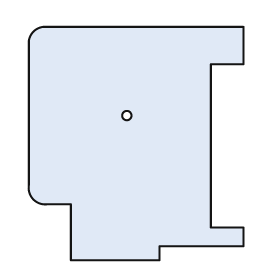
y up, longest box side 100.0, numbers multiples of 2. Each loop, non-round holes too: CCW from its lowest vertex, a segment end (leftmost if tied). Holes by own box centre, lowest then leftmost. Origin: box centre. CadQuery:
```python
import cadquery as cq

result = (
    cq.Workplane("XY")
    .moveTo(-28.0, -50.0)
    .lineTo(10.0, -50.0)
    .lineTo(10.0, -44.0)
    .lineTo(46.0, -44.0)
    .lineTo(46.0, -36.0)
    .lineTo(32.0, -36.0)
    .lineTo(32.0, 34.0)
    .lineTo(46.0, 34.0)
    .lineTo(46.0, 50.0)
    .lineTo(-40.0, 50.0)
    .threePointArc((-44.0, 48.0), (-46.0, 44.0))
    .lineTo(-46.0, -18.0)
    .threePointArc((-44.0, -24.0), (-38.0, -26.0))
    .lineTo(-28.0, -26.0)
    .close()
    .moveTo(-4.0, 12.0)
    .circle(2.0)
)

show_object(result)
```